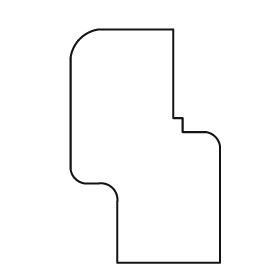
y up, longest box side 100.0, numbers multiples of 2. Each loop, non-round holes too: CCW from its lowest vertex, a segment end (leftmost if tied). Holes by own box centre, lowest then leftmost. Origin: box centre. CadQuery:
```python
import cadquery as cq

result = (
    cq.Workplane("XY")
    .moveTo(-12.0, -50.0)
    .lineTo(32.0, -50.0)
    .lineTo(32.0, 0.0)
    .threePointArc((30.0, 4.0), (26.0, 6.0))
    .lineTo(16.0, 6.0)
    .lineTo(16.0, 12.0)
    .lineTo(12.0, 12.0)
    .lineTo(12.0, 50.0)
    .lineTo(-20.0, 50.0)
    .threePointArc((-28.0, 46.0), (-32.0, 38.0))
    .lineTo(-32.0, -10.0)
    .threePointArc((-30.0, -14.0), (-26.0, -16.0))
    .lineTo(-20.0, -16.0)
    .threePointArc((-14.0, -18.0), (-12.0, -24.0))
    .close()
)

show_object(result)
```